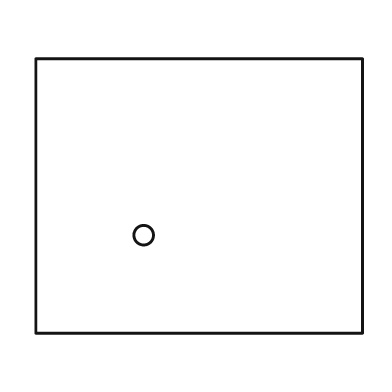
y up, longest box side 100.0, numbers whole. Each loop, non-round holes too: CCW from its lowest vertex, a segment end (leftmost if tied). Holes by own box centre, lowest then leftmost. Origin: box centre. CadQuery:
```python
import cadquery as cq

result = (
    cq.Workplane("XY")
    .moveTo(-50.0, -42.0)
    .lineTo(50.0, -42.0)
    .lineTo(50.0, 42.0)
    .lineTo(-50.0, 42.0)
    .close()
    .moveTo(-17.0, -12.0)
    .circle(3.0)
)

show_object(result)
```